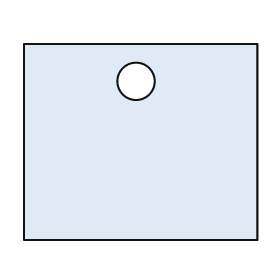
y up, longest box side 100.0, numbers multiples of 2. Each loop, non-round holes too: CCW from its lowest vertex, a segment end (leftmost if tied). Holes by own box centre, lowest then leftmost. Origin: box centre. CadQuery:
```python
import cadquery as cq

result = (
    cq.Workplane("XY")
    .moveTo(-50.0, -42.0)
    .lineTo(50.0, -42.0)
    .lineTo(50.0, 42.0)
    .lineTo(-50.0, 42.0)
    .close()
    .moveTo(-2.0, 26.0)
    .circle(8.0)
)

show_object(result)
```